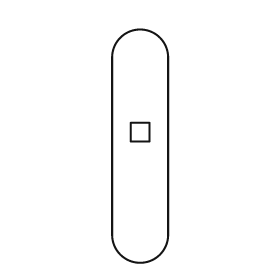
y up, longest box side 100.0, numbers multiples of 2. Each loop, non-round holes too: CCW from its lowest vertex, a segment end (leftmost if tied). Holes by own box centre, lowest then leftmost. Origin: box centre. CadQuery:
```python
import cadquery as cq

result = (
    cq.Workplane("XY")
    .moveTo(-12.0, -38.0)
    .threePointArc((0.0, -50.0), (12.0, -38.0))
    .lineTo(12.0, 38.0)
    .threePointArc((0.0, 50.0), (-12.0, 38.0))
    .close()
    .moveTo(-4.0, 2.0)
    .lineTo(4.0, 2.0)
    .lineTo(4.0, 10.0)
    .lineTo(-4.0, 10.0)
    .close()
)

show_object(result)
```